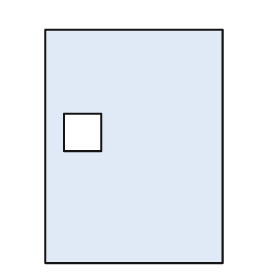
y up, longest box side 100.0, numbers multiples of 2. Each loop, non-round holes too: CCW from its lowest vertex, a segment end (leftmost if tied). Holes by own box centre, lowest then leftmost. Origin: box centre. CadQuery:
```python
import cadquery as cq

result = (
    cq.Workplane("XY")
    .moveTo(-38.0, -50.0)
    .lineTo(38.0, -50.0)
    .lineTo(38.0, 50.0)
    .lineTo(-38.0, 50.0)
    .close()
    .moveTo(-30.0, -2.0)
    .lineTo(-14.0, -2.0)
    .lineTo(-14.0, 14.0)
    .lineTo(-30.0, 14.0)
    .close()
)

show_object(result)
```